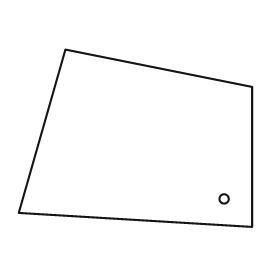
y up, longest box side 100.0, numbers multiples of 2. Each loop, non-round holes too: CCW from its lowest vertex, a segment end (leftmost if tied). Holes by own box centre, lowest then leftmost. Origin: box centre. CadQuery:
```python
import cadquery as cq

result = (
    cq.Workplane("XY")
    .moveTo(50.0, -38.0)
    .lineTo(50.0, 22.0)
    .lineTo(-30.0, 38.0)
    .lineTo(-50.0, -32.0)
    .close()
    .moveTo(38.0, -26.0)
    .circle(2.0)
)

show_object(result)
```